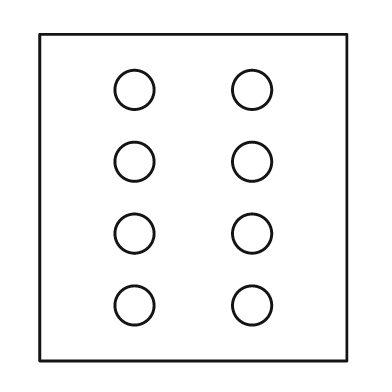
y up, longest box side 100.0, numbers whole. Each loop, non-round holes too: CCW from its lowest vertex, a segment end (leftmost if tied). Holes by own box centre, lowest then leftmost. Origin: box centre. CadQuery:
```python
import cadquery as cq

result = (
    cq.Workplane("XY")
    .moveTo(-47.0, -50.0)
    .lineTo(47.0, -50.0)
    .lineTo(47.0, 50.0)
    .lineTo(-47.0, 50.0)
    .close()
    .moveTo(-18.0, -33.0)
    .circle(6.0)
    .moveTo(18.0, -33.0)
    .circle(6.0)
    .moveTo(-18.0, -11.0)
    .circle(6.0)
    .moveTo(18.0, -11.0)
    .circle(6.0)
    .moveTo(-18.0, 11.0)
    .circle(6.0)
    .moveTo(18.0, 11.0)
    .circle(6.0)
    .moveTo(-18.0, 33.0)
    .circle(6.0)
    .moveTo(18.0, 33.0)
    .circle(6.0)
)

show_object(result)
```